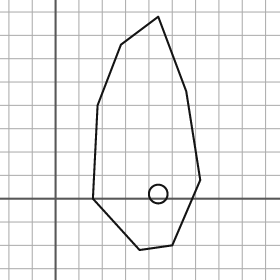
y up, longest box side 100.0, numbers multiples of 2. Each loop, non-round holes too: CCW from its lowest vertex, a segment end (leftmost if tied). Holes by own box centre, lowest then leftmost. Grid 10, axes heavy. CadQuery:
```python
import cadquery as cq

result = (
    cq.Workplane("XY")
    .moveTo(36.0, -22.0)
    .lineTo(50.0, -20.0)
    .lineTo(62.0, 8.0)
    .lineTo(56.0, 46.0)
    .lineTo(44.0, 78.0)
    .lineTo(28.0, 66.0)
    .lineTo(18.0, 40.0)
    .lineTo(16.0, 0.0)
    .close()
    .moveTo(44.0, 2.0)
    .circle(4.0)
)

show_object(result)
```